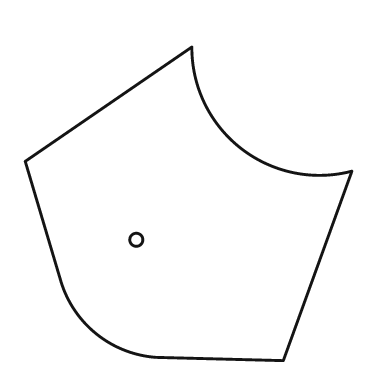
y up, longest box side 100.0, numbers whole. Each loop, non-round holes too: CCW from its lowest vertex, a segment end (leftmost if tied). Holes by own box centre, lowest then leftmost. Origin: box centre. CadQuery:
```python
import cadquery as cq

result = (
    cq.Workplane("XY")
    .moveTo(29.0, -48.0)
    .lineTo(50.0, 10.0)
    .threePointArc((16.0, 17.0), (1.0, 48.0))
    .lineTo(-50.0, 13.0)
    .lineTo(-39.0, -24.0)
    .threePointArc((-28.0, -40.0), (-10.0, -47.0))
    .close()
    .moveTo(-16.0, -11.0)
    .circle(2.0)
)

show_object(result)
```